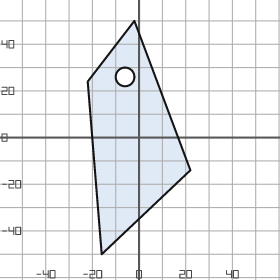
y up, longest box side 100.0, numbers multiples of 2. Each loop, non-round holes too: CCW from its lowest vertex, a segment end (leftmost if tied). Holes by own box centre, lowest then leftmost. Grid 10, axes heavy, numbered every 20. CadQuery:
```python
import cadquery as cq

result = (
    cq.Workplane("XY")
    .moveTo(-16.0, -50.0)
    .lineTo(22.0, -14.0)
    .lineTo(-2.0, 50.0)
    .lineTo(-22.0, 24.0)
    .close()
    .moveTo(-6.0, 26.0)
    .circle(4.0)
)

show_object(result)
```